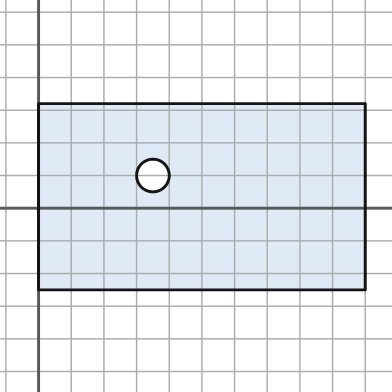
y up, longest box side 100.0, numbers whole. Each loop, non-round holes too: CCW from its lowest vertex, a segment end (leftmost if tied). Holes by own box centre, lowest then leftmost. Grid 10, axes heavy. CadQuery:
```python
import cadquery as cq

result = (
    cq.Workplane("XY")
    .moveTo(0.0, -25.0)
    .lineTo(100.0, -25.0)
    .lineTo(100.0, 32.0)
    .lineTo(0.0, 32.0)
    .close()
    .moveTo(35.0, 10.0)
    .circle(5.0)
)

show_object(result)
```